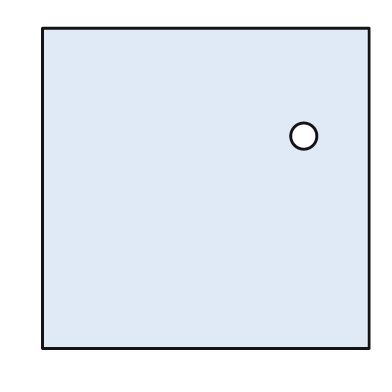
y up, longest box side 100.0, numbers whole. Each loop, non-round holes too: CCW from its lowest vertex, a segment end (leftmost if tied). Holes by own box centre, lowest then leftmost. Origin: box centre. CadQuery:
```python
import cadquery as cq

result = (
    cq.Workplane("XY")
    .moveTo(-50.0, -49.0)
    .lineTo(50.0, -49.0)
    .lineTo(50.0, 49.0)
    .lineTo(-50.0, 49.0)
    .close()
    .moveTo(30.0, 16.0)
    .circle(4.0)
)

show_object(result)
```